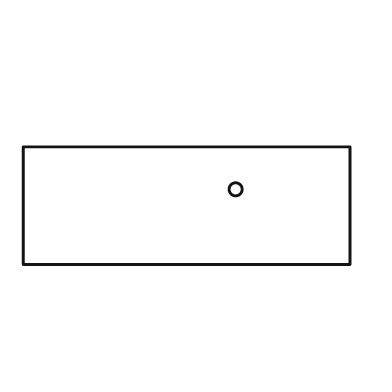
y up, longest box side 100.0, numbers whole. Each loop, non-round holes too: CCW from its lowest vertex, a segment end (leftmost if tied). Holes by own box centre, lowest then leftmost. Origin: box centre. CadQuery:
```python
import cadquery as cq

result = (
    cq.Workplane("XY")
    .moveTo(-50.0, -18.0)
    .lineTo(50.0, -18.0)
    .lineTo(50.0, 18.0)
    .lineTo(-50.0, 18.0)
    .close()
    .moveTo(15.0, 5.0)
    .circle(2.0)
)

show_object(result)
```